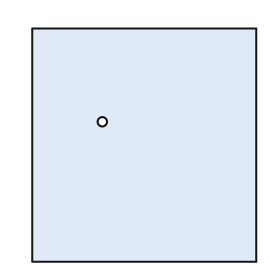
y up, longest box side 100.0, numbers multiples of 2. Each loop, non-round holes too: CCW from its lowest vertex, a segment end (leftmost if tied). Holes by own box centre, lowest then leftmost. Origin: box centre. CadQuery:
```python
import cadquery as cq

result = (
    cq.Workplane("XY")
    .moveTo(-48.0, -50.0)
    .lineTo(48.0, -50.0)
    .lineTo(48.0, 50.0)
    .lineTo(-48.0, 50.0)
    .close()
    .moveTo(-18.0, 10.0)
    .circle(2.0)
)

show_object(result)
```